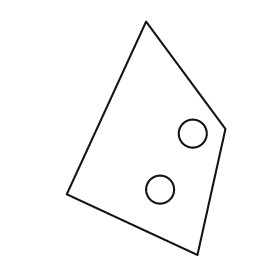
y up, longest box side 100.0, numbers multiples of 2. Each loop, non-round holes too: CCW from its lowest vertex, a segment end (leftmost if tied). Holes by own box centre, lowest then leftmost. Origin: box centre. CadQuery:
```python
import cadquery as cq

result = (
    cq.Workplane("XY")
    .moveTo(22.0, -50.0)
    .lineTo(34.0, 4.0)
    .lineTo(0.0, 50.0)
    .lineTo(-34.0, -24.0)
    .close()
    .moveTo(6.0, -22.0)
    .circle(6.0)
    .moveTo(20.0, 2.0)
    .circle(6.0)
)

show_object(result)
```